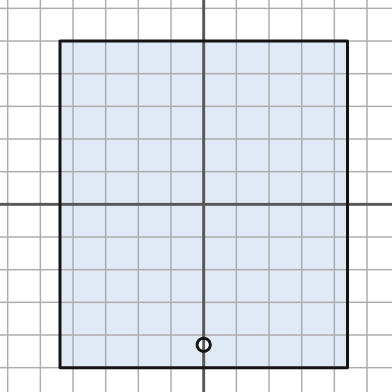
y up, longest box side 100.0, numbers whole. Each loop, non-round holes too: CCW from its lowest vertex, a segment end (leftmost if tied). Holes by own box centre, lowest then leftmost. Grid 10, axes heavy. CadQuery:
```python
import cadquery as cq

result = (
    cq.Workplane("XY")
    .moveTo(-44.0, -50.0)
    .lineTo(44.0, -50.0)
    .lineTo(44.0, 50.0)
    .lineTo(-44.0, 50.0)
    .close()
    .moveTo(0.0, -43.0)
    .circle(2.0)
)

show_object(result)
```